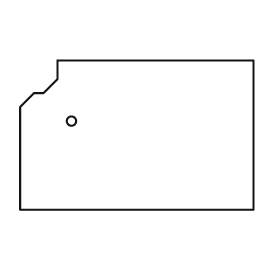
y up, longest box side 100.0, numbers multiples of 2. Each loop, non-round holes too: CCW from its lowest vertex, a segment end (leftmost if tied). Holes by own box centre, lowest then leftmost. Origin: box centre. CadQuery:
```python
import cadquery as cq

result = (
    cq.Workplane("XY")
    .moveTo(-50.0, -32.0)
    .lineTo(50.0, -32.0)
    .lineTo(50.0, 32.0)
    .lineTo(-34.0, 32.0)
    .lineTo(-34.0, 24.0)
    .lineTo(-40.0, 18.0)
    .lineTo(-44.0, 18.0)
    .lineTo(-50.0, 12.0)
    .close()
    .moveTo(-28.0, 6.0)
    .circle(2.0)
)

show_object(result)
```